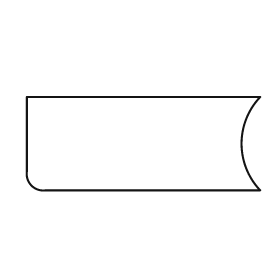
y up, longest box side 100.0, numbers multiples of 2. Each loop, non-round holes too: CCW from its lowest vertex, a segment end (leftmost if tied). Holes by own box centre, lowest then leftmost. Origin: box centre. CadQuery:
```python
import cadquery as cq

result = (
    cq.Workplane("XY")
    .moveTo(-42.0, -20.0)
    .lineTo(50.0, -20.0)
    .threePointArc((42.0, 0.0), (50.0, 20.0))
    .lineTo(-50.0, 20.0)
    .lineTo(-50.0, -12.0)
    .threePointArc((-48.0, -18.0), (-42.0, -20.0))
    .close()
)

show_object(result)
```